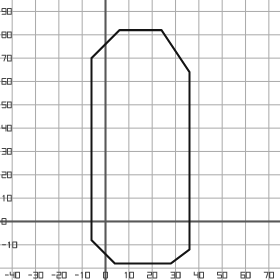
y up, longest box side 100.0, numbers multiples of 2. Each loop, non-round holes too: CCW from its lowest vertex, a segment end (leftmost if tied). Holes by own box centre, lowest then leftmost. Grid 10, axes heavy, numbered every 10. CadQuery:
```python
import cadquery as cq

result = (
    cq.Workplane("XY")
    .moveTo(4.0, -18.0)
    .lineTo(28.0, -18.0)
    .lineTo(36.0, -12.0)
    .lineTo(36.0, 64.0)
    .lineTo(24.0, 82.0)
    .lineTo(6.0, 82.0)
    .lineTo(-6.0, 70.0)
    .lineTo(-6.0, -8.0)
    .close()
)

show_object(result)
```